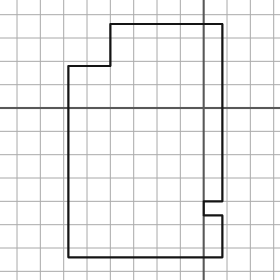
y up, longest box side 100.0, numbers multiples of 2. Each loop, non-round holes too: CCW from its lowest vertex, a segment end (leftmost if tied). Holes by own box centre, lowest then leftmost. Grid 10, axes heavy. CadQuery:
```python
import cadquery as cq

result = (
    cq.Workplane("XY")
    .moveTo(-58.0, -64.0)
    .lineTo(8.0, -64.0)
    .lineTo(8.0, -46.0)
    .lineTo(0.0, -46.0)
    .lineTo(0.0, -40.0)
    .lineTo(8.0, -40.0)
    .lineTo(8.0, 36.0)
    .lineTo(-40.0, 36.0)
    .lineTo(-40.0, 18.0)
    .lineTo(-58.0, 18.0)
    .close()
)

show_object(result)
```